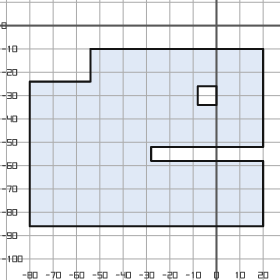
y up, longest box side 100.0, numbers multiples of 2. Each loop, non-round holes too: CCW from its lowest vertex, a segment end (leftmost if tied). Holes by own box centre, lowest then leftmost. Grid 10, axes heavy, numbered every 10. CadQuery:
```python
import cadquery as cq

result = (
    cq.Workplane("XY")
    .moveTo(-80.0, -86.0)
    .lineTo(20.0, -86.0)
    .lineTo(20.0, -58.0)
    .lineTo(-28.0, -58.0)
    .lineTo(-28.0, -52.0)
    .lineTo(20.0, -52.0)
    .lineTo(20.0, -10.0)
    .lineTo(-54.0, -10.0)
    .lineTo(-54.0, -24.0)
    .lineTo(-80.0, -24.0)
    .close()
    .moveTo(-8.0, -34.0)
    .lineTo(0.0, -34.0)
    .lineTo(0.0, -26.0)
    .lineTo(-8.0, -26.0)
    .close()
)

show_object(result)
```